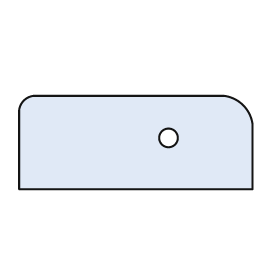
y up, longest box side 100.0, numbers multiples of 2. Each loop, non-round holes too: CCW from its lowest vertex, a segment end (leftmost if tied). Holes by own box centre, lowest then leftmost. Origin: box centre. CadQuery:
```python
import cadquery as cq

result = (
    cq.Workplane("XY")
    .moveTo(-50.0, -20.0)
    .lineTo(50.0, -20.0)
    .lineTo(50.0, 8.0)
    .threePointArc((46.0, 16.0), (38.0, 20.0))
    .lineTo(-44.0, 20.0)
    .threePointArc((-48.0, 18.0), (-50.0, 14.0))
    .close()
    .moveTo(14.0, 2.0)
    .circle(4.0)
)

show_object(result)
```